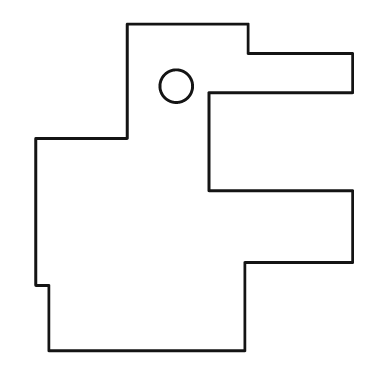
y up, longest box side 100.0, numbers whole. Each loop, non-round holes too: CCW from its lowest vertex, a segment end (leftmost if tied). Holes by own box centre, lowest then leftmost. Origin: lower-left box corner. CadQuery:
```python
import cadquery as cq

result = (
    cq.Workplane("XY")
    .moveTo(4.0, 0.0)
    .lineTo(64.0, 0.0)
    .lineTo(64.0, 27.0)
    .lineTo(97.0, 27.0)
    .lineTo(97.0, 49.0)
    .lineTo(53.0, 49.0)
    .lineTo(53.0, 79.0)
    .lineTo(97.0, 79.0)
    .lineTo(97.0, 91.0)
    .lineTo(65.0, 91.0)
    .lineTo(65.0, 100.0)
    .lineTo(28.0, 100.0)
    .lineTo(28.0, 65.0)
    .lineTo(0.0, 65.0)
    .lineTo(0.0, 20.0)
    .lineTo(4.0, 20.0)
    .close()
    .moveTo(43.0, 81.0)
    .circle(5.0)
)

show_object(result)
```